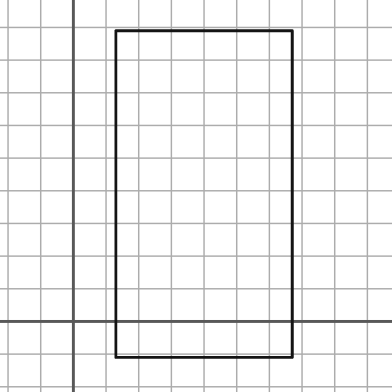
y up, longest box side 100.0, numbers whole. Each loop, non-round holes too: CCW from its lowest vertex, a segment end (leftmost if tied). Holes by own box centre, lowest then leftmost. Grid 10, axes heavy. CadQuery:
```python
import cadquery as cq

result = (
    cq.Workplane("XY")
    .moveTo(13.0, -11.0)
    .lineTo(67.0, -11.0)
    .lineTo(67.0, 89.0)
    .lineTo(13.0, 89.0)
    .close()
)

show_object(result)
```